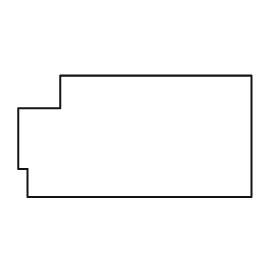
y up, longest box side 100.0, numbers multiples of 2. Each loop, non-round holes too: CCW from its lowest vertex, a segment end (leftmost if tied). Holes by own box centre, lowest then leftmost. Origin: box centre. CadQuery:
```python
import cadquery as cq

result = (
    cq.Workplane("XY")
    .moveTo(-46.0, -26.0)
    .lineTo(50.0, -26.0)
    .lineTo(50.0, 26.0)
    .lineTo(-32.0, 26.0)
    .lineTo(-32.0, 12.0)
    .lineTo(-50.0, 12.0)
    .lineTo(-50.0, -14.0)
    .lineTo(-46.0, -14.0)
    .close()
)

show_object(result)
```